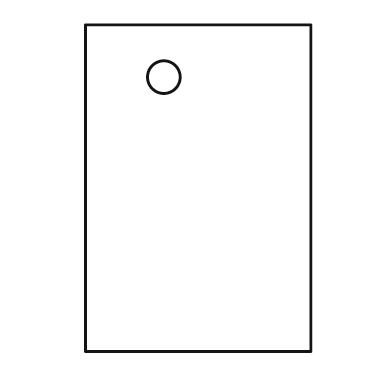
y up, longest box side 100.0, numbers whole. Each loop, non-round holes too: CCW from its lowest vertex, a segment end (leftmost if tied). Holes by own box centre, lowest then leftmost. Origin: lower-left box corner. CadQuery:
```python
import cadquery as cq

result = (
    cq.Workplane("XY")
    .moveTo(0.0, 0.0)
    .lineTo(69.0, 0.0)
    .lineTo(69.0, 100.0)
    .lineTo(0.0, 100.0)
    .close()
    .moveTo(24.0, 84.0)
    .circle(5.0)
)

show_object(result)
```